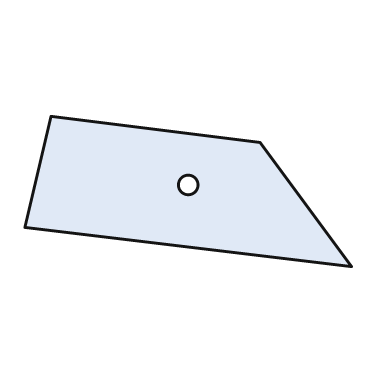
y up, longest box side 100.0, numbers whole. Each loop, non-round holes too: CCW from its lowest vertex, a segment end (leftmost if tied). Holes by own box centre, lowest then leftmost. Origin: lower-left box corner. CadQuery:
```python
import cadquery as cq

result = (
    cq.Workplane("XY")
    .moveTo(100.0, 0.0)
    .lineTo(72.0, 38.0)
    .lineTo(8.0, 46.0)
    .lineTo(0.0, 12.0)
    .close()
    .moveTo(50.0, 25.0)
    .circle(3.0)
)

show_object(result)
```